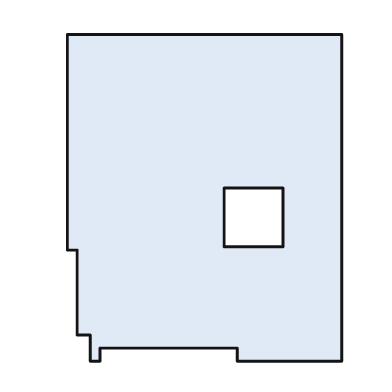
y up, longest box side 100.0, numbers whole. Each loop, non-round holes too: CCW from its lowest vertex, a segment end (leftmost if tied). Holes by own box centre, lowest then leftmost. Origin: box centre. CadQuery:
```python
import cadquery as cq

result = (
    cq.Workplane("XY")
    .moveTo(-35.0, -50.0)
    .lineTo(-32.0, -50.0)
    .lineTo(-32.0, -46.0)
    .lineTo(10.0, -46.0)
    .lineTo(10.0, -50.0)
    .lineTo(42.0, -50.0)
    .lineTo(42.0, 50.0)
    .lineTo(-42.0, 50.0)
    .lineTo(-42.0, -16.0)
    .lineTo(-39.0, -16.0)
    .lineTo(-39.0, -42.0)
    .lineTo(-35.0, -42.0)
    .close()
    .moveTo(6.0, -15.0)
    .lineTo(24.0, -15.0)
    .lineTo(24.0, 3.0)
    .lineTo(6.0, 3.0)
    .close()
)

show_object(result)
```